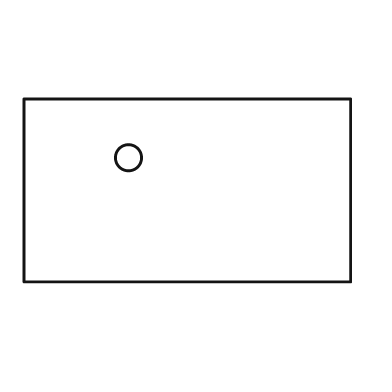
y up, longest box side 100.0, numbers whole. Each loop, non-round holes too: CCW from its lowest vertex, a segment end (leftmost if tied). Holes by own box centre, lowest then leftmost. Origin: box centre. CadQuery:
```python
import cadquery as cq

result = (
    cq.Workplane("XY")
    .moveTo(-50.0, -28.0)
    .lineTo(50.0, -28.0)
    .lineTo(50.0, 28.0)
    .lineTo(-50.0, 28.0)
    .close()
    .moveTo(-18.0, 10.0)
    .circle(4.0)
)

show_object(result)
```